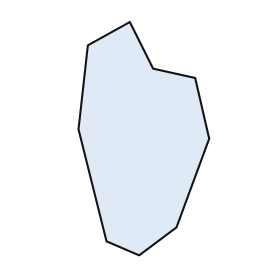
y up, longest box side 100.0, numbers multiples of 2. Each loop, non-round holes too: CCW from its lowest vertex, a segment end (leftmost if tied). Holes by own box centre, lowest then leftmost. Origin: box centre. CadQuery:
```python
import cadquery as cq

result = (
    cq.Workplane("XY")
    .moveTo(-2.0, -50.0)
    .lineTo(14.0, -38.0)
    .lineTo(28.0, 0.0)
    .lineTo(22.0, 26.0)
    .lineTo(4.0, 30.0)
    .lineTo(-6.0, 50.0)
    .lineTo(-24.0, 40.0)
    .lineTo(-28.0, 4.0)
    .lineTo(-16.0, -44.0)
    .close()
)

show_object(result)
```